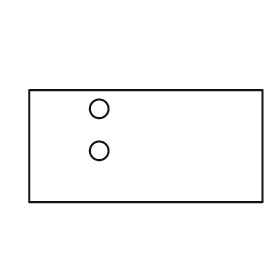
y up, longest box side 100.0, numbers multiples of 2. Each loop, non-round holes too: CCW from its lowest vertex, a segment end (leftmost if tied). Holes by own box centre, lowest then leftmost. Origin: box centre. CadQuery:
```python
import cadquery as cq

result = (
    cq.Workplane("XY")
    .moveTo(-50.0, -24.0)
    .lineTo(50.0, -24.0)
    .lineTo(50.0, 24.0)
    .lineTo(-50.0, 24.0)
    .close()
    .moveTo(-20.0, -2.0)
    .circle(4.0)
    .moveTo(-20.0, 16.0)
    .circle(4.0)
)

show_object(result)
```